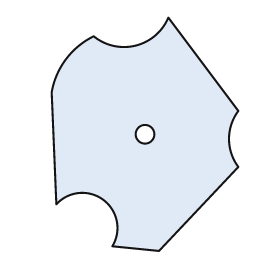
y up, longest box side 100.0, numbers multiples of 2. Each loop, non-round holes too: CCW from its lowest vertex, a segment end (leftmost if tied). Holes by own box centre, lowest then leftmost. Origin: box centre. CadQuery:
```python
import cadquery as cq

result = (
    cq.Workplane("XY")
    .moveTo(6.0, -50.0)
    .lineTo(40.0, -14.0)
    .threePointArc((36.0, -2.0), (40.0, 10.0))
    .lineTo(10.0, 50.0)
    .threePointArc((-4.0, 38.0), (-22.0, 42.0))
    .threePointArc((-34.0, 32.0), (-40.0, 18.0))
    .lineTo(-38.0, -30.0)
    .threePointArc((-18.0, -28.0), (-14.0, -48.0))
    .close()
    .moveTo(0.0, 0.0)
    .circle(4.0)
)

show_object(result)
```